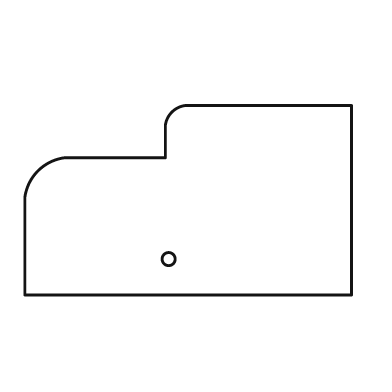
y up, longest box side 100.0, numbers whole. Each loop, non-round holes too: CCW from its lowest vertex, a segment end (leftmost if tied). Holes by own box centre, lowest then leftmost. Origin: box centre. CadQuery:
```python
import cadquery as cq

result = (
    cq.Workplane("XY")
    .moveTo(-50.0, -29.0)
    .lineTo(50.0, -29.0)
    .lineTo(50.0, 29.0)
    .lineTo(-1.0, 29.0)
    .threePointArc((-5.0, 27.0), (-7.0, 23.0))
    .lineTo(-7.0, 13.0)
    .lineTo(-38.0, 13.0)
    .threePointArc((-46.0, 9.0), (-50.0, 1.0))
    .close()
    .moveTo(-6.0, -18.0)
    .circle(2.0)
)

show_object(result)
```